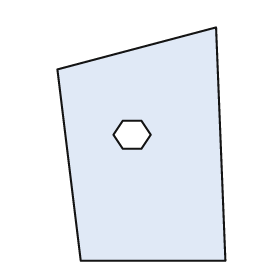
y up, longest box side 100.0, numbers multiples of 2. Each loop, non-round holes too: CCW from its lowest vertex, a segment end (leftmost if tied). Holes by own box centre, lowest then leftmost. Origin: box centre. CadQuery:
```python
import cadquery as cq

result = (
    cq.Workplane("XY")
    .moveTo(-26.0, -50.0)
    .lineTo(36.0, -50.0)
    .lineTo(32.0, 50.0)
    .lineTo(-36.0, 32.0)
    .close()
    .moveTo(-8.0, -2.0)
    .lineTo(0.0, -2.0)
    .lineTo(4.0, 4.0)
    .lineTo(0.0, 10.0)
    .lineTo(-8.0, 10.0)
    .lineTo(-12.0, 4.0)
    .close()
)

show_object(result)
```